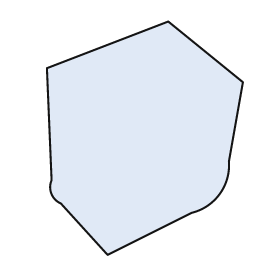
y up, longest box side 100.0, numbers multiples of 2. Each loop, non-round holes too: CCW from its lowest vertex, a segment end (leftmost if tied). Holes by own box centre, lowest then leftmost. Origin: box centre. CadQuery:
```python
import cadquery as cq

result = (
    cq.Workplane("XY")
    .moveTo(-16.0, -50.0)
    .lineTo(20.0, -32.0)
    .threePointArc((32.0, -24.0), (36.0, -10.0))
    .lineTo(42.0, 24.0)
    .lineTo(10.0, 50.0)
    .lineTo(-42.0, 30.0)
    .lineTo(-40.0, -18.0)
    .threePointArc((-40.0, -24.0), (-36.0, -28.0))
    .close()
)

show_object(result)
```